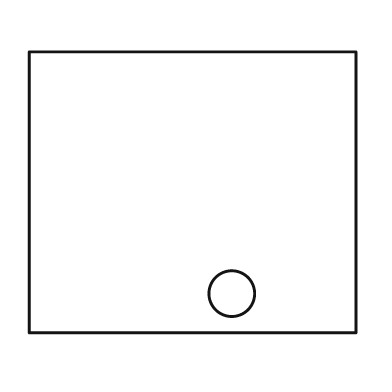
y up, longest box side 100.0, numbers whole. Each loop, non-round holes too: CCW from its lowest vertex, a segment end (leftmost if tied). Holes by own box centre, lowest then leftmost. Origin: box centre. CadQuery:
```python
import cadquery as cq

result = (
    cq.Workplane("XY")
    .moveTo(-50.0, -43.0)
    .lineTo(50.0, -43.0)
    .lineTo(50.0, 43.0)
    .lineTo(-50.0, 43.0)
    .close()
    .moveTo(12.0, -31.0)
    .circle(7.0)
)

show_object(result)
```